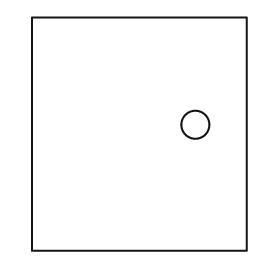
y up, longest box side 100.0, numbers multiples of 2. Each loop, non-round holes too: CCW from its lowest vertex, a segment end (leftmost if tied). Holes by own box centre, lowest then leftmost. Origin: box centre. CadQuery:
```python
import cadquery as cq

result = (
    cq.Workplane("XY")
    .moveTo(-46.0, -50.0)
    .lineTo(46.0, -50.0)
    .lineTo(46.0, 50.0)
    .lineTo(-46.0, 50.0)
    .close()
    .moveTo(24.0, 4.0)
    .circle(6.0)
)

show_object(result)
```